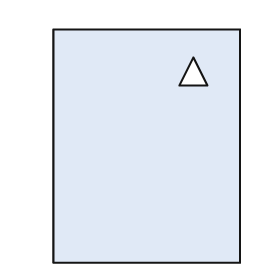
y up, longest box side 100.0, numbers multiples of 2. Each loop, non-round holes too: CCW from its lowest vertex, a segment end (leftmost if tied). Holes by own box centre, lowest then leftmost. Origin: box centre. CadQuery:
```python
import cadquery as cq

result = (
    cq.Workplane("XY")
    .moveTo(-40.0, -50.0)
    .lineTo(40.0, -50.0)
    .lineTo(40.0, 50.0)
    .lineTo(-40.0, 50.0)
    .close()
    .moveTo(14.0, 26.0)
    .lineTo(26.0, 26.0)
    .lineTo(20.0, 38.0)
    .close()
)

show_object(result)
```